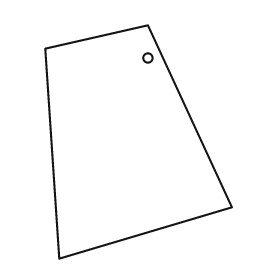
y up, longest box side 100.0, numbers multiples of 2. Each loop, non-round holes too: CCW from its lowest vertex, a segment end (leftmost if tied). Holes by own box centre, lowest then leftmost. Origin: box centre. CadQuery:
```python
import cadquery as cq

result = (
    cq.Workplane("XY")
    .moveTo(-34.0, -50.0)
    .lineTo(40.0, -28.0)
    .lineTo(4.0, 50.0)
    .lineTo(-40.0, 40.0)
    .close()
    .moveTo(4.0, 36.0)
    .circle(2.0)
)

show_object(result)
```